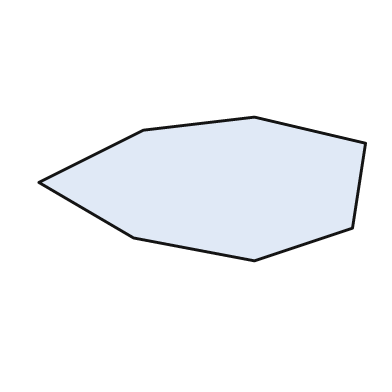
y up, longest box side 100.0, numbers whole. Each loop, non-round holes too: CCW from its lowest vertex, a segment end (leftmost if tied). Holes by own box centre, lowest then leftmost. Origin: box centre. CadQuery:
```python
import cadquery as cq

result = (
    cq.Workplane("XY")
    .moveTo(16.0, -22.0)
    .lineTo(46.0, -12.0)
    .lineTo(50.0, 14.0)
    .lineTo(16.0, 22.0)
    .lineTo(-18.0, 18.0)
    .lineTo(-50.0, 2.0)
    .lineTo(-21.0, -15.0)
    .close()
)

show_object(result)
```